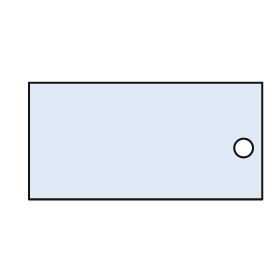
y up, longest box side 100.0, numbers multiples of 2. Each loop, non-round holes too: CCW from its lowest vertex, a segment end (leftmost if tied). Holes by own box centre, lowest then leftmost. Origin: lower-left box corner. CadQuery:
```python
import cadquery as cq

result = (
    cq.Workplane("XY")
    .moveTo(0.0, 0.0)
    .lineTo(100.0, 0.0)
    .lineTo(100.0, 50.0)
    .lineTo(0.0, 50.0)
    .close()
    .moveTo(92.0, 22.0)
    .circle(4.0)
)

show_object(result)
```